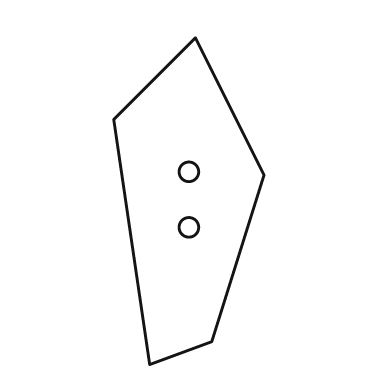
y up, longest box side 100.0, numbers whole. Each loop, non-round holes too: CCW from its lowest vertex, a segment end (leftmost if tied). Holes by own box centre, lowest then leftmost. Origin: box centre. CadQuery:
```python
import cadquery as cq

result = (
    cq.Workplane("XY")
    .moveTo(-12.0, -50.0)
    .lineTo(7.0, -43.0)
    .lineTo(23.0, 8.0)
    .lineTo(2.0, 50.0)
    .lineTo(-23.0, 25.0)
    .close()
    .moveTo(0.0, -8.0)
    .circle(3.0)
    .moveTo(0.0, 9.0)
    .circle(3.0)
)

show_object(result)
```